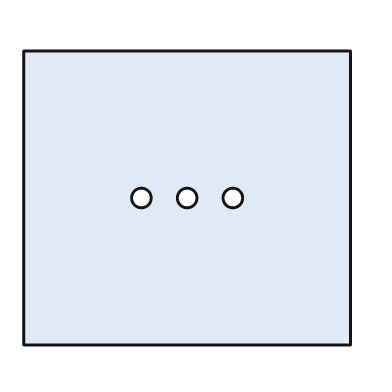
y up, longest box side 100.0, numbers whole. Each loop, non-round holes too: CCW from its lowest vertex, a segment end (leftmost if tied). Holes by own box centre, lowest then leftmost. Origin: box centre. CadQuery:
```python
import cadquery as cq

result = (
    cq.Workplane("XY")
    .moveTo(-50.0, -45.0)
    .lineTo(50.0, -45.0)
    .lineTo(50.0, 45.0)
    .lineTo(-50.0, 45.0)
    .close()
    .moveTo(-14.0, 0.0)
    .circle(3.0)
    .moveTo(0.0, 0.0)
    .circle(3.0)
    .moveTo(14.0, 0.0)
    .circle(3.0)
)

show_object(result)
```